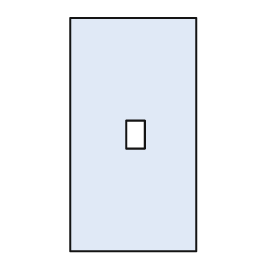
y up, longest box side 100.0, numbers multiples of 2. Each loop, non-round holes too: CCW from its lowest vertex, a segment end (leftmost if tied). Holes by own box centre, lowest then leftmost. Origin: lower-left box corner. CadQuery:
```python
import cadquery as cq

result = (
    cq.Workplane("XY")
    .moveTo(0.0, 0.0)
    .lineTo(54.0, 0.0)
    .lineTo(54.0, 100.0)
    .lineTo(0.0, 100.0)
    .close()
    .moveTo(24.0, 44.0)
    .lineTo(32.0, 44.0)
    .lineTo(32.0, 56.0)
    .lineTo(24.0, 56.0)
    .close()
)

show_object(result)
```